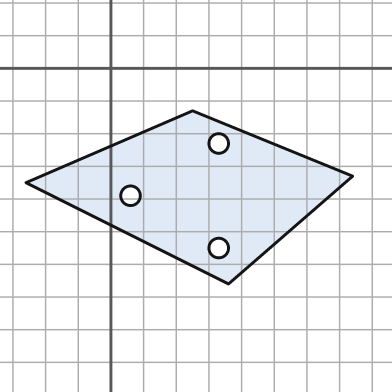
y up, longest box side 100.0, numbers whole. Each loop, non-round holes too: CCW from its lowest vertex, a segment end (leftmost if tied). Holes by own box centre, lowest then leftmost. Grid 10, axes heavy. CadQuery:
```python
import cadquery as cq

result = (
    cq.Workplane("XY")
    .moveTo(36.0, -66.0)
    .lineTo(74.0, -33.0)
    .lineTo(25.0, -13.0)
    .lineTo(-26.0, -35.0)
    .close()
    .moveTo(33.0, -55.0)
    .circle(3.0)
    .moveTo(6.0, -39.0)
    .circle(3.0)
    .moveTo(33.0, -23.0)
    .circle(3.0)
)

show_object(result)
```